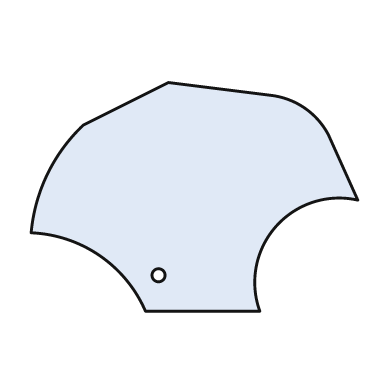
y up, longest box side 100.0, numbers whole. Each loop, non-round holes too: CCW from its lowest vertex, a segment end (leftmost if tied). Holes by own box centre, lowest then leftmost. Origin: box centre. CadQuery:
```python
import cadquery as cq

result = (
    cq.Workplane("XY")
    .moveTo(-15.0, -35.0)
    .lineTo(20.0, -35.0)
    .threePointArc((25.0, -9.0), (50.0, -1.0))
    .lineTo(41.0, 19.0)
    .threePointArc((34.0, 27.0), (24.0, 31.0))
    .lineTo(-8.0, 35.0)
    .lineTo(-34.0, 22.0)
    .threePointArc((-45.0, 7.0), (-50.0, -11.0))
    .threePointArc((-29.0, -18.0), (-15.0, -35.0))
    .close()
    .moveTo(-11.0, -24.0)
    .circle(2.0)
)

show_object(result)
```